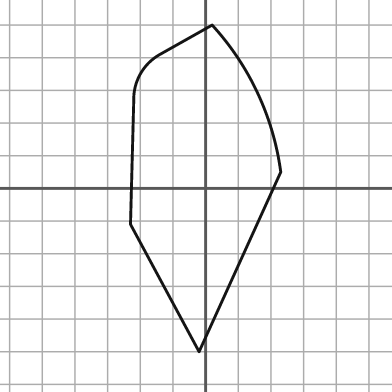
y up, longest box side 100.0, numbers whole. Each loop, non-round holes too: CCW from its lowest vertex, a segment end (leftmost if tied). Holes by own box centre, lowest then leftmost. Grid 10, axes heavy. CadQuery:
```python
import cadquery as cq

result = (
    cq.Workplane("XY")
    .moveTo(-2.0, -50.0)
    .lineTo(23.0, 5.0)
    .threePointArc((16.0, 29.0), (2.0, 50.0))
    .lineTo(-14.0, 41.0)
    .threePointArc((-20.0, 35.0), (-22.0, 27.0))
    .lineTo(-23.0, -11.0)
    .close()
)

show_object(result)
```